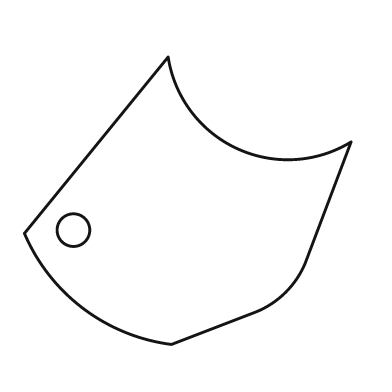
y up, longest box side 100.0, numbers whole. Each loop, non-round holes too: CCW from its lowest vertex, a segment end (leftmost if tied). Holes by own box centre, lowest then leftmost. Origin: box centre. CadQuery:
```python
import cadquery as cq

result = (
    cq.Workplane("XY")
    .moveTo(-5.0, -44.0)
    .lineTo(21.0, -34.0)
    .threePointArc((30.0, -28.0), (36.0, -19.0))
    .lineTo(50.0, 18.0)
    .threePointArc((15.0, 16.0), (-6.0, 44.0))
    .lineTo(-50.0, -10.0)
    .threePointArc((-32.0, -33.0), (-5.0, -44.0))
    .close()
    .moveTo(-35.0, -9.0)
    .circle(5.0)
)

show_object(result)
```